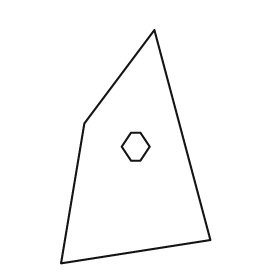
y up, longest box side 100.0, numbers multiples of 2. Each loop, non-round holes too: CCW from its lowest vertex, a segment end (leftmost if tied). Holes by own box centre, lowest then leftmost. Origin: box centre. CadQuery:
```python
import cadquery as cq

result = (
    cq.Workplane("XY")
    .moveTo(-32.0, -50.0)
    .lineTo(32.0, -40.0)
    .lineTo(8.0, 50.0)
    .lineTo(-22.0, 10.0)
    .close()
    .moveTo(-2.0, -6.0)
    .lineTo(2.0, -6.0)
    .lineTo(6.0, 0.0)
    .lineTo(2.0, 6.0)
    .lineTo(-2.0, 6.0)
    .lineTo(-6.0, 0.0)
    .close()
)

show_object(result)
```